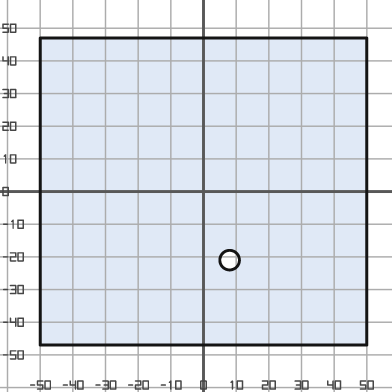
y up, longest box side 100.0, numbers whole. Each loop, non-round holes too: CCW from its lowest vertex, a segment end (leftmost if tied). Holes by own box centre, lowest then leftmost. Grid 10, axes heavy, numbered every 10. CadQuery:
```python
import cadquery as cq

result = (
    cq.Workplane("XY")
    .moveTo(-50.0, -47.0)
    .lineTo(50.0, -47.0)
    .lineTo(50.0, 47.0)
    .lineTo(-50.0, 47.0)
    .close()
    .moveTo(8.0, -21.0)
    .circle(3.0)
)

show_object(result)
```